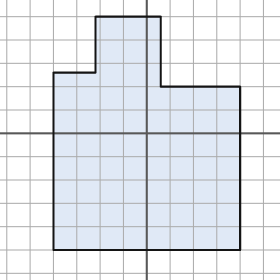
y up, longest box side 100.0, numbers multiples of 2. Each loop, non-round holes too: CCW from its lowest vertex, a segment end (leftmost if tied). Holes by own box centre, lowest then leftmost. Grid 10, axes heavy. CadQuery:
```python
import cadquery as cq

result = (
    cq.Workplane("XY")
    .moveTo(-40.0, -50.0)
    .lineTo(40.0, -50.0)
    .lineTo(40.0, 20.0)
    .lineTo(6.0, 20.0)
    .lineTo(6.0, 50.0)
    .lineTo(-22.0, 50.0)
    .lineTo(-22.0, 26.0)
    .lineTo(-40.0, 26.0)
    .close()
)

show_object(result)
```